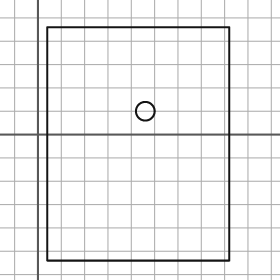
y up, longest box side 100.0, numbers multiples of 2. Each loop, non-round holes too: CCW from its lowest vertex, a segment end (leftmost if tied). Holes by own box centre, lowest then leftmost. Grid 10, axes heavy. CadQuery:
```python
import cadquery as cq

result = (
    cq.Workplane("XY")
    .moveTo(4.0, -54.0)
    .lineTo(82.0, -54.0)
    .lineTo(82.0, 46.0)
    .lineTo(4.0, 46.0)
    .close()
    .moveTo(46.0, 10.0)
    .circle(4.0)
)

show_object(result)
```